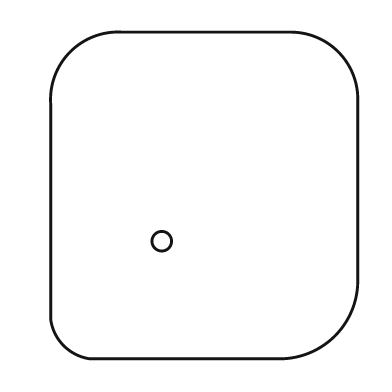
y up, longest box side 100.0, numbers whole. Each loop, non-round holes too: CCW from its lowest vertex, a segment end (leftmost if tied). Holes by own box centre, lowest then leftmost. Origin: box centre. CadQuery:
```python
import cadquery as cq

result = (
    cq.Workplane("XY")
    .moveTo(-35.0, -50.0)
    .lineTo(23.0, -50.0)
    .threePointArc((40.0, -43.0), (47.0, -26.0))
    .lineTo(47.0, 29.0)
    .threePointArc((41.0, 44.0), (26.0, 50.0))
    .lineTo(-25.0, 50.0)
    .threePointArc((-41.0, 44.0), (-47.0, 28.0))
    .lineTo(-47.0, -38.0)
    .threePointArc((-43.0, -46.0), (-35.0, -50.0))
    .close()
    .moveTo(-13.0, -14.0)
    .circle(3.0)
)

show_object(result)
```